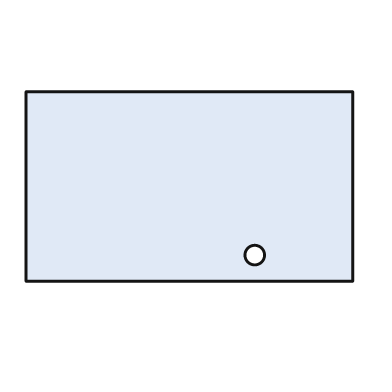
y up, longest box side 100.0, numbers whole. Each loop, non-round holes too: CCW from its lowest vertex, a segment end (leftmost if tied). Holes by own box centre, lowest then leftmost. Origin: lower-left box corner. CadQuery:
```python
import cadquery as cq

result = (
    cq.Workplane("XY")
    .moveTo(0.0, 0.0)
    .lineTo(100.0, 0.0)
    .lineTo(100.0, 58.0)
    .lineTo(0.0, 58.0)
    .close()
    .moveTo(70.0, 8.0)
    .circle(3.0)
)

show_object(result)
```